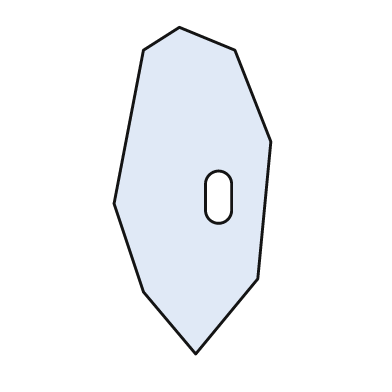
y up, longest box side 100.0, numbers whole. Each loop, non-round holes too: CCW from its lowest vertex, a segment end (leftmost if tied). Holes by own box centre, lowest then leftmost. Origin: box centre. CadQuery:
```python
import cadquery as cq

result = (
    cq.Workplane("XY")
    .moveTo(1.0, -50.0)
    .lineTo(20.0, -27.0)
    .lineTo(24.0, 15.0)
    .lineTo(13.0, 43.0)
    .lineTo(-4.0, 50.0)
    .lineTo(-15.0, 43.0)
    .lineTo(-24.0, -4.0)
    .lineTo(-15.0, -31.0)
    .close()
    .moveTo(4.0, -6.0)
    .threePointArc((8.0, -10.0), (12.0, -6.0))
    .lineTo(12.0, 2.0)
    .threePointArc((8.0, 6.0), (4.0, 2.0))
    .close()
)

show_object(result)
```